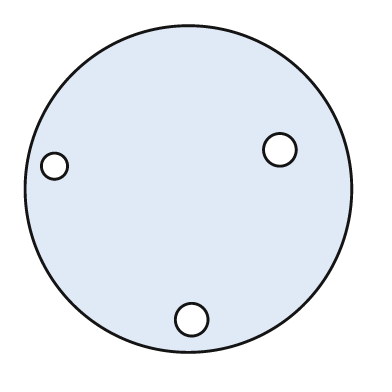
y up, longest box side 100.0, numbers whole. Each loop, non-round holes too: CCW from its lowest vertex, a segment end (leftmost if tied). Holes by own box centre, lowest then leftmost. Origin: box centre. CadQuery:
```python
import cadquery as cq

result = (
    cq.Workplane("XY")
    .moveTo(0.0, 0.0)
    .circle(50.0)
    .moveTo(1.0, -40.0)
    .circle(5.0)
    .moveTo(-41.0, 7.0)
    .circle(4.0)
    .moveTo(28.0, 12.0)
    .circle(5.0)
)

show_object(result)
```